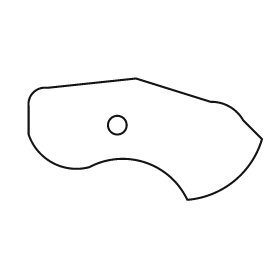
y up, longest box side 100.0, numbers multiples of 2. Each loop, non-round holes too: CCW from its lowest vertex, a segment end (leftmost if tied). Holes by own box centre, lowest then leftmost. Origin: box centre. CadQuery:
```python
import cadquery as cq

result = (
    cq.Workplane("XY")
    .moveTo(18.0, -26.0)
    .threePointArc((38.0, -18.0), (50.0, 0.0))
    .lineTo(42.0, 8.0)
    .threePointArc((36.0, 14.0), (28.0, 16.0))
    .lineTo(-4.0, 26.0)
    .lineTo(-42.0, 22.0)
    .threePointArc((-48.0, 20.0), (-50.0, 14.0))
    .lineTo(-50.0, 2.0)
    .threePointArc((-40.0, -10.0), (-24.0, -12.0))
    .threePointArc((0.0, -10.0), (18.0, -26.0))
    .close()
    .moveTo(-12.0, 6.0)
    .circle(4.0)
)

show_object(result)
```